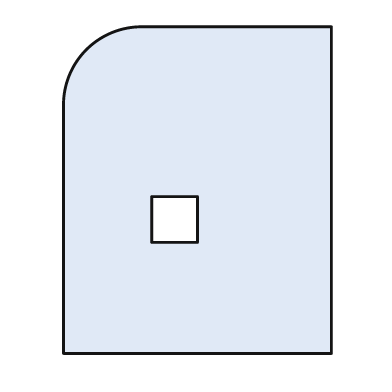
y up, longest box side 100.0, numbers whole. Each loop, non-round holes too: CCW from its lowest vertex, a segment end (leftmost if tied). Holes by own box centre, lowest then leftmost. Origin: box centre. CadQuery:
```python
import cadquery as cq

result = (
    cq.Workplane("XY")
    .moveTo(-41.0, -50.0)
    .lineTo(41.0, -50.0)
    .lineTo(41.0, 50.0)
    .lineTo(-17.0, 50.0)
    .threePointArc((-34.0, 43.0), (-41.0, 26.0))
    .close()
    .moveTo(-14.0, -16.0)
    .lineTo(0.0, -16.0)
    .lineTo(0.0, -2.0)
    .lineTo(-14.0, -2.0)
    .close()
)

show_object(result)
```